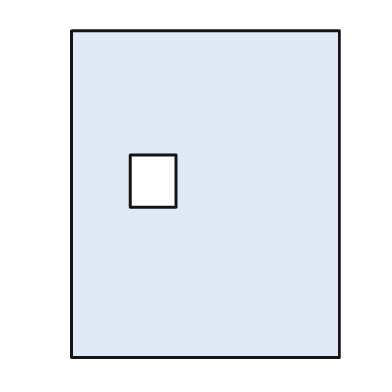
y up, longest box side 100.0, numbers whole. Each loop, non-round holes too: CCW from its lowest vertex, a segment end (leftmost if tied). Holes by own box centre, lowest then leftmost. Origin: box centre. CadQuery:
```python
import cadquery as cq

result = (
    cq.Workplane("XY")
    .moveTo(-41.0, -50.0)
    .lineTo(41.0, -50.0)
    .lineTo(41.0, 50.0)
    .lineTo(-41.0, 50.0)
    .close()
    .moveTo(-23.0, -4.0)
    .lineTo(-9.0, -4.0)
    .lineTo(-9.0, 12.0)
    .lineTo(-23.0, 12.0)
    .close()
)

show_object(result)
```